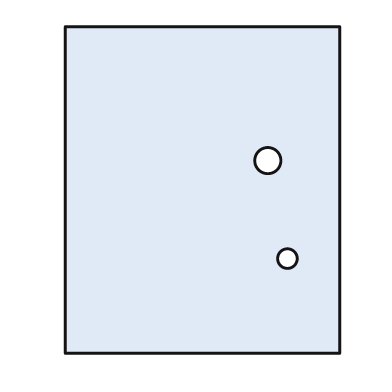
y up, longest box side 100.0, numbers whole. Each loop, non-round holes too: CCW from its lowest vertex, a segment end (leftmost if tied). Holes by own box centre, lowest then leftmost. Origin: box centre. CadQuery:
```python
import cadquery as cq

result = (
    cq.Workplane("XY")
    .moveTo(-42.0, -50.0)
    .lineTo(42.0, -50.0)
    .lineTo(42.0, 50.0)
    .lineTo(-42.0, 50.0)
    .close()
    .moveTo(26.0, -21.0)
    .circle(3.0)
    .moveTo(20.0, 9.0)
    .circle(4.0)
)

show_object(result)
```